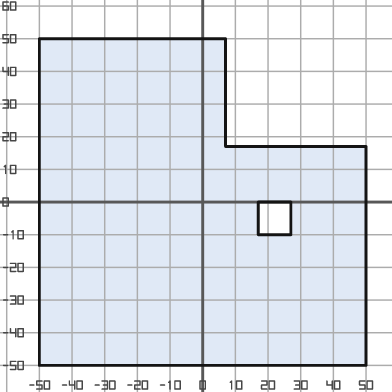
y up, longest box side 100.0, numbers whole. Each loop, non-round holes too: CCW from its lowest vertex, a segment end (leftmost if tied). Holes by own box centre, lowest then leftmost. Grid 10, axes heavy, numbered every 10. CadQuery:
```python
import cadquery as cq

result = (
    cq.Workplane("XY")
    .moveTo(-50.0, -50.0)
    .lineTo(50.0, -50.0)
    .lineTo(50.0, 17.0)
    .lineTo(7.0, 17.0)
    .lineTo(7.0, 50.0)
    .lineTo(-50.0, 50.0)
    .close()
    .moveTo(17.0, -10.0)
    .lineTo(27.0, -10.0)
    .lineTo(27.0, 0.0)
    .lineTo(17.0, 0.0)
    .close()
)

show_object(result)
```